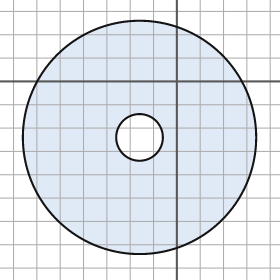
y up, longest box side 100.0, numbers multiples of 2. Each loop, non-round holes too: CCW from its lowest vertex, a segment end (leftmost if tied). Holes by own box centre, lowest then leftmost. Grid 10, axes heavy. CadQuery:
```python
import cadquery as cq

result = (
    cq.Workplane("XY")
    .moveTo(-16.0, -24.0)
    .circle(50.0)
    .moveTo(-16.0, -24.0)
    .circle(10.0)
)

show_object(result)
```